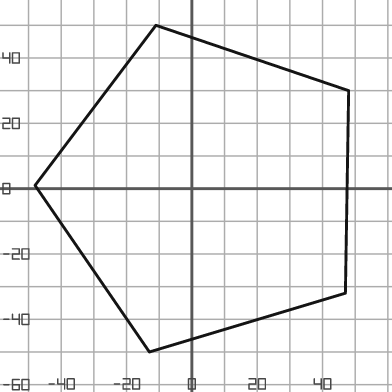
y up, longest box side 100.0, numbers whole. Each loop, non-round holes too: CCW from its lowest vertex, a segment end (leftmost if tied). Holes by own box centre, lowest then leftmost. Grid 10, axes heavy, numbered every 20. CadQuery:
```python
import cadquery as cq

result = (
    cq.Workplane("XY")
    .moveTo(-13.0, -50.0)
    .lineTo(47.0, -32.0)
    .lineTo(48.0, 30.0)
    .lineTo(-11.0, 50.0)
    .lineTo(-48.0, 1.0)
    .close()
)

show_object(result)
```